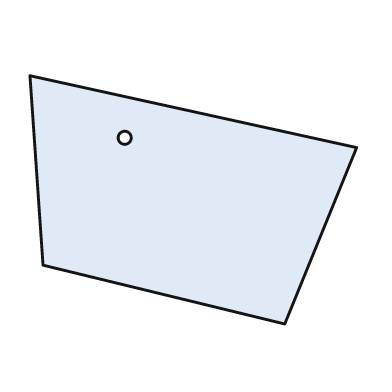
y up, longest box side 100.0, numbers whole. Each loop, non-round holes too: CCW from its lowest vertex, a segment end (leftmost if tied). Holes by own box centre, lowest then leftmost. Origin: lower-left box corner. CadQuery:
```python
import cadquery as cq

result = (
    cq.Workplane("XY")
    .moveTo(78.0, 0.0)
    .lineTo(100.0, 54.0)
    .lineTo(0.0, 76.0)
    .lineTo(4.0, 18.0)
    .close()
    .moveTo(29.0, 57.0)
    .circle(2.0)
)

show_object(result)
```